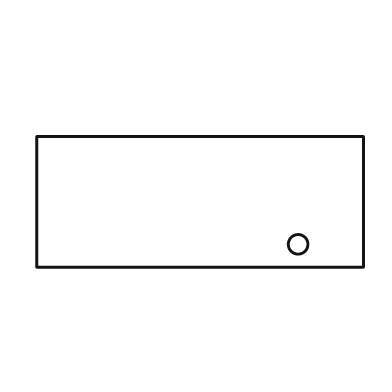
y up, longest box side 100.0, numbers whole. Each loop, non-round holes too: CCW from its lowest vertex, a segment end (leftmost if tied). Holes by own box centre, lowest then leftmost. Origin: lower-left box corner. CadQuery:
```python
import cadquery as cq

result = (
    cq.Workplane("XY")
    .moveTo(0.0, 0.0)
    .lineTo(100.0, 0.0)
    .lineTo(100.0, 40.0)
    .lineTo(0.0, 40.0)
    .close()
    .moveTo(80.0, 7.0)
    .circle(3.0)
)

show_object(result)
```